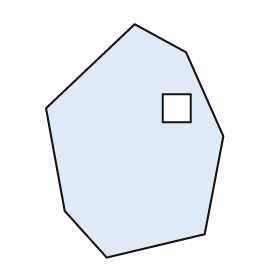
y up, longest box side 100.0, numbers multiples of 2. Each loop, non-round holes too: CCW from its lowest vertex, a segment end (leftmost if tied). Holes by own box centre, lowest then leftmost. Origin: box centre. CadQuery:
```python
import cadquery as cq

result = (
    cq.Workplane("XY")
    .moveTo(-12.0, -50.0)
    .lineTo(30.0, -40.0)
    .lineTo(38.0, 2.0)
    .lineTo(22.0, 38.0)
    .lineTo(0.0, 50.0)
    .lineTo(-38.0, 14.0)
    .lineTo(-30.0, -30.0)
    .close()
    .moveTo(12.0, 8.0)
    .lineTo(24.0, 8.0)
    .lineTo(24.0, 20.0)
    .lineTo(12.0, 20.0)
    .close()
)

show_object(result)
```